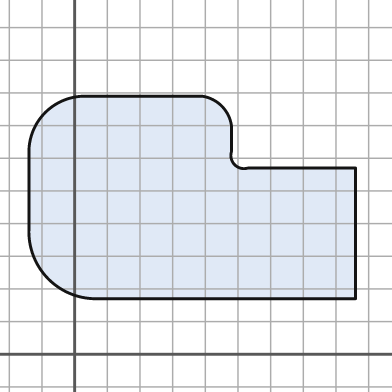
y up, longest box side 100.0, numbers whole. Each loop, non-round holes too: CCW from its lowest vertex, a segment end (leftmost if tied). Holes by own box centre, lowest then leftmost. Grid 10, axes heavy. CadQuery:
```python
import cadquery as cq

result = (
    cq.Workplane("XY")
    .moveTo(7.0, 17.0)
    .lineTo(86.0, 17.0)
    .lineTo(86.0, 57.0)
    .lineTo(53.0, 57.0)
    .threePointArc((49.0, 58.0), (48.0, 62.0))
    .lineTo(48.0, 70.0)
    .threePointArc((45.0, 76.0), (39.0, 79.0))
    .lineTo(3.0, 79.0)
    .threePointArc((-9.0, 74.0), (-14.0, 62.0))
    .lineTo(-14.0, 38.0)
    .threePointArc((-8.0, 23.0), (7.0, 17.0))
    .close()
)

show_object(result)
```